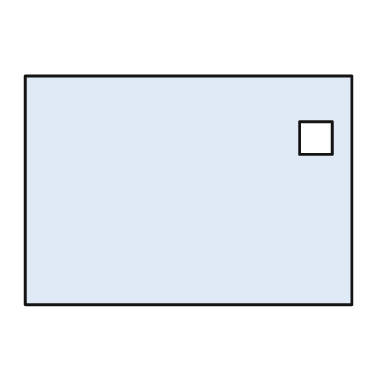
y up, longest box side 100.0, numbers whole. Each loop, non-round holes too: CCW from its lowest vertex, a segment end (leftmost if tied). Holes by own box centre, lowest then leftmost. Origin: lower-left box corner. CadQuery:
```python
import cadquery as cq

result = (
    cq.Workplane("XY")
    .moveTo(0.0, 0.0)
    .lineTo(100.0, 0.0)
    .lineTo(100.0, 70.0)
    .lineTo(0.0, 70.0)
    .close()
    .moveTo(84.0, 46.0)
    .lineTo(94.0, 46.0)
    .lineTo(94.0, 56.0)
    .lineTo(84.0, 56.0)
    .close()
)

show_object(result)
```